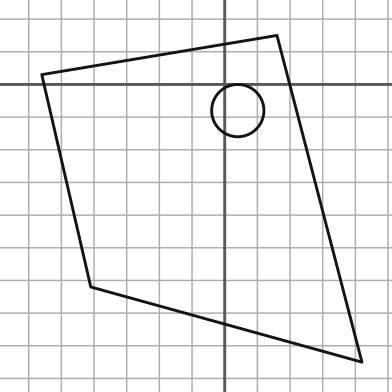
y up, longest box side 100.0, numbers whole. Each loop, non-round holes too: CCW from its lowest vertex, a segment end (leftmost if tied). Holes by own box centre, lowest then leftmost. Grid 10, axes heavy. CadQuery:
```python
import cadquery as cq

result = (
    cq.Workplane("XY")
    .moveTo(42.0, -85.0)
    .lineTo(16.0, 15.0)
    .lineTo(-56.0, 3.0)
    .lineTo(-41.0, -62.0)
    .close()
    .moveTo(4.0, -8.0)
    .circle(8.0)
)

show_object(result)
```